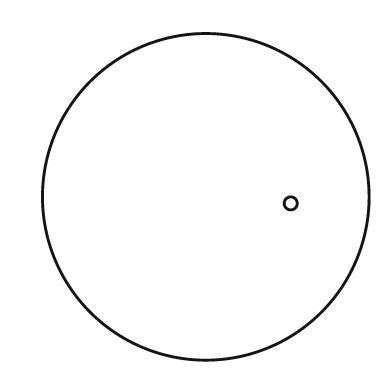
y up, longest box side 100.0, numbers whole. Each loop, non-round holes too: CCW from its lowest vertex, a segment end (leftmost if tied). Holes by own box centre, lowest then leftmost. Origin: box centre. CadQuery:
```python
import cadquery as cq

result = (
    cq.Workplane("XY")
    .moveTo(0.0, 0.0)
    .circle(50.0)
    .moveTo(26.0, -2.0)
    .circle(2.0)
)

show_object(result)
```